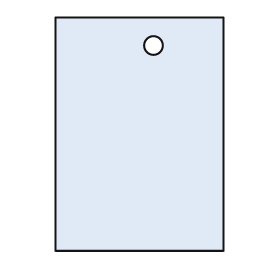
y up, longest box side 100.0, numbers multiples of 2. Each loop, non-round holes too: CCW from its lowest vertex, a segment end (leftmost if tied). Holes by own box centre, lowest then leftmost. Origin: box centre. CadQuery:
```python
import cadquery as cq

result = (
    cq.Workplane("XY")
    .moveTo(-36.0, -50.0)
    .lineTo(36.0, -50.0)
    .lineTo(36.0, 50.0)
    .lineTo(-36.0, 50.0)
    .close()
    .moveTo(6.0, 38.0)
    .circle(4.0)
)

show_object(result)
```